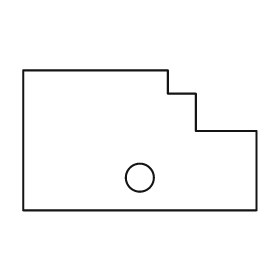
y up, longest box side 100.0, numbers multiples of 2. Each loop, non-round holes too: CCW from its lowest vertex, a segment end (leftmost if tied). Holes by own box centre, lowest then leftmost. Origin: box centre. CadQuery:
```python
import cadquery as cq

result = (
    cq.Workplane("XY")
    .moveTo(-50.0, -30.0)
    .lineTo(50.0, -30.0)
    .lineTo(50.0, 4.0)
    .lineTo(24.0, 4.0)
    .lineTo(24.0, 20.0)
    .lineTo(12.0, 20.0)
    .lineTo(12.0, 30.0)
    .lineTo(-50.0, 30.0)
    .close()
    .moveTo(0.0, -16.0)
    .circle(6.0)
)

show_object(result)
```